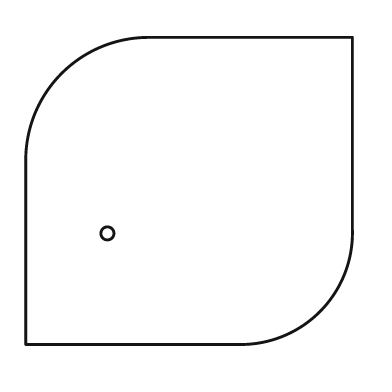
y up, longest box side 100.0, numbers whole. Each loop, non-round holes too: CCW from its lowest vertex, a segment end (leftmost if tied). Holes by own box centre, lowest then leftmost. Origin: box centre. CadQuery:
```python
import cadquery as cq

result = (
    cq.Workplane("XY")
    .moveTo(-50.0, -47.0)
    .lineTo(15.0, -47.0)
    .threePointArc((40.0, -37.0), (50.0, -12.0))
    .lineTo(50.0, 47.0)
    .lineTo(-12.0, 47.0)
    .threePointArc((-39.0, 36.0), (-50.0, 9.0))
    .close()
    .moveTo(-25.0, -13.0)
    .circle(2.0)
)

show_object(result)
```